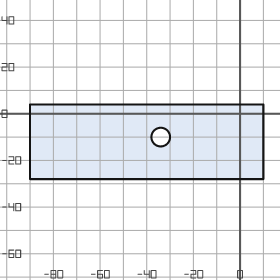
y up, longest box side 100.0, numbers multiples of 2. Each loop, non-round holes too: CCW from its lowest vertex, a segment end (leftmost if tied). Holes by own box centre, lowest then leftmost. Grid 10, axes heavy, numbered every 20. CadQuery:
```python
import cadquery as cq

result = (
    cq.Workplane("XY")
    .moveTo(-90.0, -28.0)
    .lineTo(10.0, -28.0)
    .lineTo(10.0, 4.0)
    .lineTo(-90.0, 4.0)
    .close()
    .moveTo(-34.0, -10.0)
    .circle(4.0)
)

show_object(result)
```